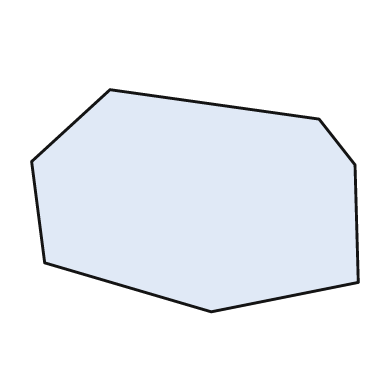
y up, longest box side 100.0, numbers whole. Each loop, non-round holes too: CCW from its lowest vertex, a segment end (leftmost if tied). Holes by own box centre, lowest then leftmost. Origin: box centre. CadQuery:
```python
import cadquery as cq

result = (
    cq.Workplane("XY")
    .moveTo(5.0, -34.0)
    .lineTo(50.0, -25.0)
    .lineTo(49.0, 11.0)
    .lineTo(38.0, 25.0)
    .lineTo(-26.0, 34.0)
    .lineTo(-50.0, 12.0)
    .lineTo(-46.0, -19.0)
    .close()
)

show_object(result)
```